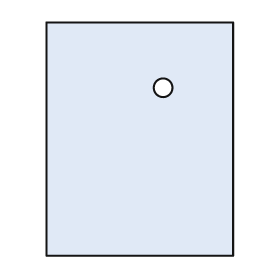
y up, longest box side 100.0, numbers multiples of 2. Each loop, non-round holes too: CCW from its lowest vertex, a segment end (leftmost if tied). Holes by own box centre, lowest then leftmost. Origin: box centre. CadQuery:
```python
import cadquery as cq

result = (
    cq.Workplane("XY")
    .moveTo(-40.0, -50.0)
    .lineTo(40.0, -50.0)
    .lineTo(40.0, 50.0)
    .lineTo(-40.0, 50.0)
    .close()
    .moveTo(10.0, 22.0)
    .circle(4.0)
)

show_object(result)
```